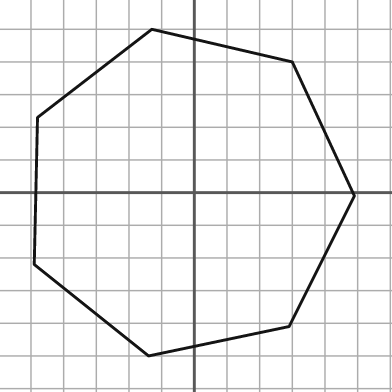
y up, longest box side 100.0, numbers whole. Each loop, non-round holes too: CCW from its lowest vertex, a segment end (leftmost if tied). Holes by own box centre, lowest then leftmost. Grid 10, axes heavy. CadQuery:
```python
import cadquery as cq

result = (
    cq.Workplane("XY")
    .moveTo(-14.0, -50.0)
    .lineTo(29.0, -41.0)
    .lineTo(49.0, -1.0)
    .lineTo(30.0, 40.0)
    .lineTo(-13.0, 50.0)
    .lineTo(-48.0, 23.0)
    .lineTo(-49.0, -22.0)
    .close()
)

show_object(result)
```